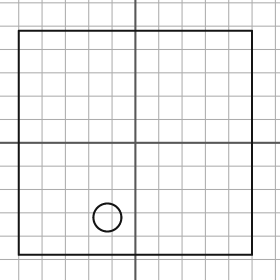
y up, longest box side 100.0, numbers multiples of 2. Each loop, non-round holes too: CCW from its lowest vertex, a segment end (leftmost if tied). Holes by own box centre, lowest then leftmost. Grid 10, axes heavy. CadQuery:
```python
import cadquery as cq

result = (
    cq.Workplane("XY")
    .moveTo(-50.0, -48.0)
    .lineTo(50.0, -48.0)
    .lineTo(50.0, 48.0)
    .lineTo(-50.0, 48.0)
    .close()
    .moveTo(-12.0, -32.0)
    .circle(6.0)
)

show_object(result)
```